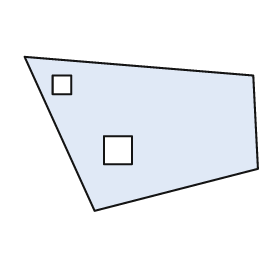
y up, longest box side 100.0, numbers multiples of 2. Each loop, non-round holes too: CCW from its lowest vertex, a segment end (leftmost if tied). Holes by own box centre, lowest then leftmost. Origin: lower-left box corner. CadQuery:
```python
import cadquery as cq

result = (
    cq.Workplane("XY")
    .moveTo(30.0, 0.0)
    .lineTo(100.0, 18.0)
    .lineTo(98.0, 58.0)
    .lineTo(0.0, 66.0)
    .close()
    .moveTo(34.0, 20.0)
    .lineTo(46.0, 20.0)
    .lineTo(46.0, 32.0)
    .lineTo(34.0, 32.0)
    .close()
    .moveTo(12.0, 50.0)
    .lineTo(20.0, 50.0)
    .lineTo(20.0, 58.0)
    .lineTo(12.0, 58.0)
    .close()
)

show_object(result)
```